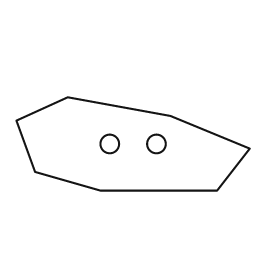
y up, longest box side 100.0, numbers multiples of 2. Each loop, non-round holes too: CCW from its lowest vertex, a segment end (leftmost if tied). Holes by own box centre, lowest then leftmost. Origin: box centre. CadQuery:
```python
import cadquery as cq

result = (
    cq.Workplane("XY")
    .moveTo(-14.0, -20.0)
    .lineTo(36.0, -20.0)
    .lineTo(50.0, -2.0)
    .lineTo(16.0, 12.0)
    .lineTo(-28.0, 20.0)
    .lineTo(-50.0, 10.0)
    .lineTo(-42.0, -12.0)
    .close()
    .moveTo(-10.0, 0.0)
    .circle(4.0)
    .moveTo(10.0, 0.0)
    .circle(4.0)
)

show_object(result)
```